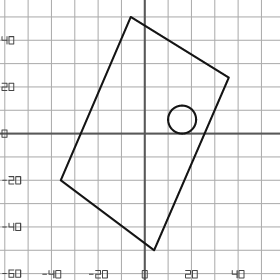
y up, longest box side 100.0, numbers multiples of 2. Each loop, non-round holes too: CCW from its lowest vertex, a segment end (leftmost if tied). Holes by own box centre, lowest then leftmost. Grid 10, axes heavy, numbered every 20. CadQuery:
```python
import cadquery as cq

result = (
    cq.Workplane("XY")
    .moveTo(4.0, -50.0)
    .lineTo(36.0, 24.0)
    .lineTo(-6.0, 50.0)
    .lineTo(-36.0, -20.0)
    .close()
    .moveTo(16.0, 6.0)
    .circle(6.0)
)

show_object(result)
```